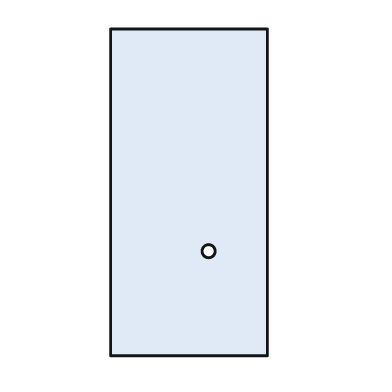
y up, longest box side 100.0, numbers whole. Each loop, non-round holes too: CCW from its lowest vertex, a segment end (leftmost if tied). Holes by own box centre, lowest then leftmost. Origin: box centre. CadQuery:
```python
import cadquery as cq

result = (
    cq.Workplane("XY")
    .moveTo(-24.0, -50.0)
    .lineTo(24.0, -50.0)
    .lineTo(24.0, 50.0)
    .lineTo(-24.0, 50.0)
    .close()
    .moveTo(6.0, -18.0)
    .circle(2.0)
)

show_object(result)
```